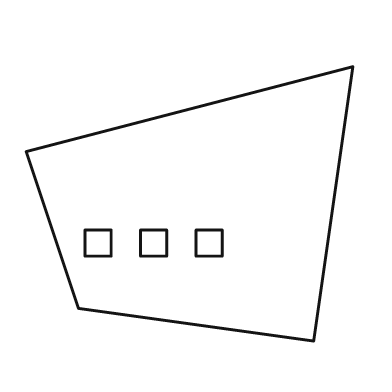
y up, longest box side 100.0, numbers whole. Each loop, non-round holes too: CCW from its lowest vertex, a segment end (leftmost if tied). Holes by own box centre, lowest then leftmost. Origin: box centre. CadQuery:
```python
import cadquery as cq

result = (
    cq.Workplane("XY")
    .moveTo(38.0, -42.0)
    .lineTo(50.0, 42.0)
    .lineTo(-50.0, 16.0)
    .lineTo(-34.0, -32.0)
    .close()
    .moveTo(-32.0, -16.0)
    .lineTo(-24.0, -16.0)
    .lineTo(-24.0, -8.0)
    .lineTo(-32.0, -8.0)
    .close()
    .moveTo(-15.0, -16.0)
    .lineTo(-7.0, -16.0)
    .lineTo(-7.0, -8.0)
    .lineTo(-15.0, -8.0)
    .close()
    .moveTo(2.0, -16.0)
    .lineTo(10.0, -16.0)
    .lineTo(10.0, -8.0)
    .lineTo(2.0, -8.0)
    .close()
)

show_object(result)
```